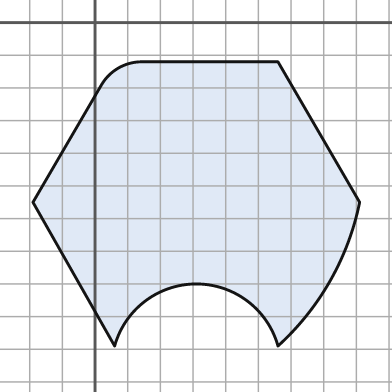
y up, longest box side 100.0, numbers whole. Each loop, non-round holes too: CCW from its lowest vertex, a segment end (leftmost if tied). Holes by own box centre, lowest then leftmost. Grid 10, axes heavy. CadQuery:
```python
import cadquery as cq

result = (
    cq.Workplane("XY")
    .moveTo(6.0, -99.0)
    .threePointArc((31.0, -80.0), (56.0, -99.0))
    .threePointArc((72.0, -79.0), (81.0, -55.0))
    .lineTo(56.0, -12.0)
    .lineTo(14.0, -12.0)
    .threePointArc((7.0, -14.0), (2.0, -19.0))
    .lineTo(-19.0, -55.0)
    .close()
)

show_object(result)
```